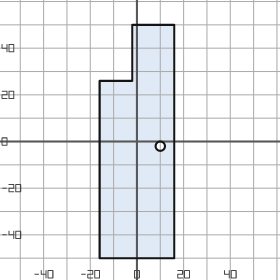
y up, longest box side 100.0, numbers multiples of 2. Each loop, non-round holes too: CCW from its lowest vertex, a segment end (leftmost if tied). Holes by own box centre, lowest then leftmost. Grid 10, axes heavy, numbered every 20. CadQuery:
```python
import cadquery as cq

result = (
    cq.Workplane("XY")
    .moveTo(-16.0, -50.0)
    .lineTo(16.0, -50.0)
    .lineTo(16.0, 50.0)
    .lineTo(-2.0, 50.0)
    .lineTo(-2.0, 26.0)
    .lineTo(-16.0, 26.0)
    .close()
    .moveTo(10.0, -2.0)
    .circle(2.0)
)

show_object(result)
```